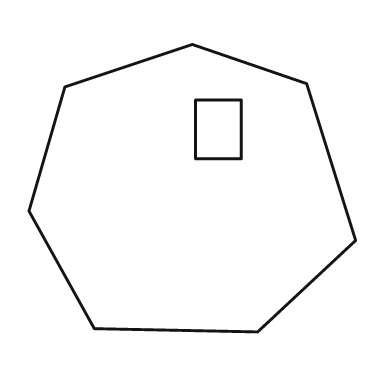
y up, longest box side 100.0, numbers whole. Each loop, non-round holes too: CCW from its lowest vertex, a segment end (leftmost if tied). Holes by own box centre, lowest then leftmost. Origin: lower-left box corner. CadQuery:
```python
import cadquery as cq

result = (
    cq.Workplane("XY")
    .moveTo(70.0, 0.0)
    .lineTo(100.0, 28.0)
    .lineTo(85.0, 76.0)
    .lineTo(50.0, 88.0)
    .lineTo(11.0, 75.0)
    .lineTo(0.0, 37.0)
    .lineTo(20.0, 1.0)
    .close()
    .moveTo(51.0, 53.0)
    .lineTo(65.0, 53.0)
    .lineTo(65.0, 71.0)
    .lineTo(51.0, 71.0)
    .close()
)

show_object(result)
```